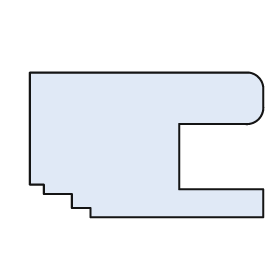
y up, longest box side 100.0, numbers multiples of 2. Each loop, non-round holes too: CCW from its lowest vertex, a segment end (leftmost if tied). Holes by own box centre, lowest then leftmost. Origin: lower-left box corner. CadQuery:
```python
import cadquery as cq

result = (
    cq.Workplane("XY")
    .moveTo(26.0, 0.0)
    .lineTo(100.0, 0.0)
    .lineTo(100.0, 12.0)
    .lineTo(64.0, 12.0)
    .lineTo(64.0, 40.0)
    .lineTo(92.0, 40.0)
    .threePointArc((98.0, 42.0), (100.0, 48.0))
    .lineTo(100.0, 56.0)
    .threePointArc((98.0, 60.0), (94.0, 62.0))
    .lineTo(0.0, 62.0)
    .lineTo(0.0, 14.0)
    .lineTo(6.0, 14.0)
    .lineTo(6.0, 10.0)
    .lineTo(18.0, 10.0)
    .lineTo(18.0, 4.0)
    .lineTo(26.0, 4.0)
    .close()
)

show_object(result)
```